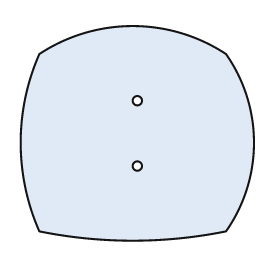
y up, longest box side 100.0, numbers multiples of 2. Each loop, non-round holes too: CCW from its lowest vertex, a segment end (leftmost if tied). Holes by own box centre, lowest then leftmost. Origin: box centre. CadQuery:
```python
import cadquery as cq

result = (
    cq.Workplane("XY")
    .moveTo(-42.0, -42.0)
    .threePointArc((-2.0, -46.0), (38.0, -42.0))
    .threePointArc((50.0, -4.0), (38.0, 34.0))
    .threePointArc((-2.0, 46.0), (-42.0, 34.0))
    .threePointArc((-50.0, -4.0), (-42.0, -42.0))
    .close()
    .moveTo(0.0, -14.0)
    .circle(2.0)
    .moveTo(0.0, 14.0)
    .circle(2.0)
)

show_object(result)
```